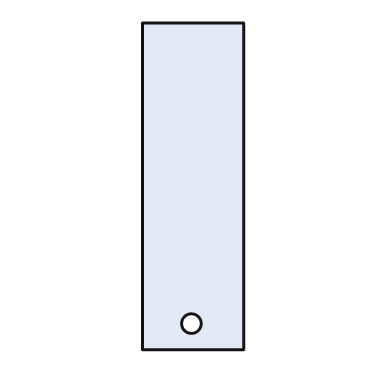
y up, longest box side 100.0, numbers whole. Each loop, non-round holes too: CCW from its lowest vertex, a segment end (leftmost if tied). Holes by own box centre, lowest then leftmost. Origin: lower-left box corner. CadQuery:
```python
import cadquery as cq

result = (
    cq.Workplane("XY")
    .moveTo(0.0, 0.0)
    .lineTo(31.0, 0.0)
    .lineTo(31.0, 100.0)
    .lineTo(0.0, 100.0)
    .close()
    .moveTo(15.0, 8.0)
    .circle(3.0)
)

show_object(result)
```